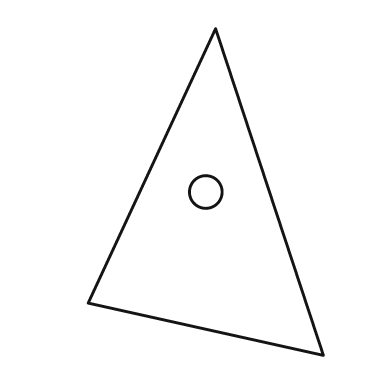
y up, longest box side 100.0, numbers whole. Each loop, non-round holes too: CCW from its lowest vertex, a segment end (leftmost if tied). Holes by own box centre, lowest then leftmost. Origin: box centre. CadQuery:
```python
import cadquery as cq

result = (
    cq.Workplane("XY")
    .moveTo(36.0, -50.0)
    .lineTo(3.0, 50.0)
    .lineTo(-36.0, -34.0)
    .close()
    .moveTo(0.0, 0.0)
    .circle(5.0)
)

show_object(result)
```